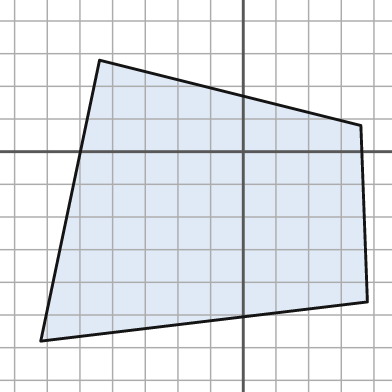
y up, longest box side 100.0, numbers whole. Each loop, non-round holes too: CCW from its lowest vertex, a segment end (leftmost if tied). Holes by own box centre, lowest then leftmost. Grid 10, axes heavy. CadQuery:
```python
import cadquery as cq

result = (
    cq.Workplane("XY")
    .moveTo(-62.0, -58.0)
    .lineTo(38.0, -46.0)
    .lineTo(36.0, 8.0)
    .lineTo(-44.0, 28.0)
    .close()
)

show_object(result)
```